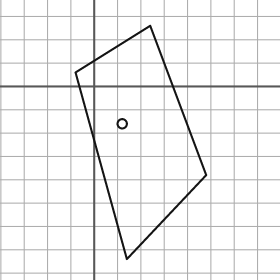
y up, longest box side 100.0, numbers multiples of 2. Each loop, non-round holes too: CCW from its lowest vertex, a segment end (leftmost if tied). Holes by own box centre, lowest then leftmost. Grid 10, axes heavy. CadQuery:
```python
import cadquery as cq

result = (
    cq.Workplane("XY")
    .moveTo(14.0, -74.0)
    .lineTo(48.0, -38.0)
    .lineTo(24.0, 26.0)
    .lineTo(-8.0, 6.0)
    .close()
    .moveTo(12.0, -16.0)
    .circle(2.0)
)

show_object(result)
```